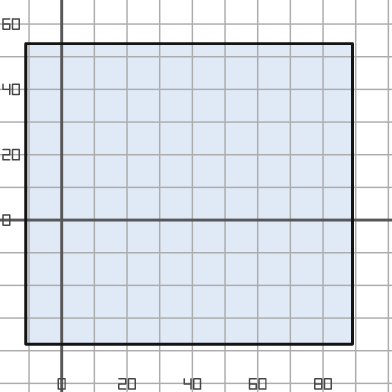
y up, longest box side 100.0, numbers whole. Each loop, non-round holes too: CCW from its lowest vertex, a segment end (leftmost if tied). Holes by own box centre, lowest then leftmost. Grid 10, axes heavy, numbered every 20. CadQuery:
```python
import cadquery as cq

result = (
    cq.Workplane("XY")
    .moveTo(-11.0, -38.0)
    .lineTo(89.0, -38.0)
    .lineTo(89.0, 54.0)
    .lineTo(-11.0, 54.0)
    .close()
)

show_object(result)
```